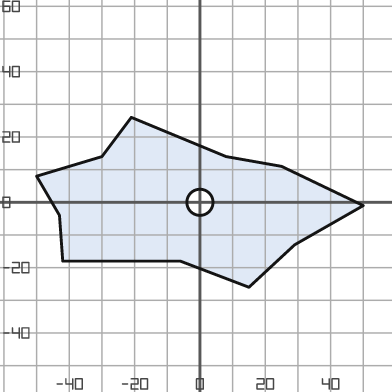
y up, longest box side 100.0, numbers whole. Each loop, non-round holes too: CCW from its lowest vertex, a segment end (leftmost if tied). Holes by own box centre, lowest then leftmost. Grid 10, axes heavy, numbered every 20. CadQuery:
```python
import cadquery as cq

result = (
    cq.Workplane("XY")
    .moveTo(15.0, -26.0)
    .lineTo(29.0, -13.0)
    .lineTo(50.0, -1.0)
    .lineTo(25.0, 11.0)
    .lineTo(8.0, 14.0)
    .lineTo(-21.0, 26.0)
    .lineTo(-30.0, 14.0)
    .lineTo(-50.0, 8.0)
    .lineTo(-43.0, -4.0)
    .lineTo(-42.0, -18.0)
    .lineTo(-6.0, -18.0)
    .close()
    .moveTo(0.0, 0.0)
    .circle(4.0)
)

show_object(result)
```